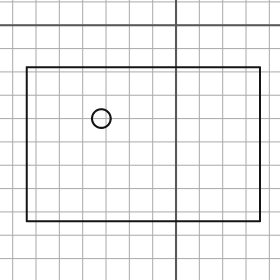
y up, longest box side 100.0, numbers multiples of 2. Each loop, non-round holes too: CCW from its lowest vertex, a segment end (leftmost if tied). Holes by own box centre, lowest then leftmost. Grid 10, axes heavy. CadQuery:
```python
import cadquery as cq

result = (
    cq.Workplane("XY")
    .moveTo(-64.0, -84.0)
    .lineTo(36.0, -84.0)
    .lineTo(36.0, -18.0)
    .lineTo(-64.0, -18.0)
    .close()
    .moveTo(-32.0, -40.0)
    .circle(4.0)
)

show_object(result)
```